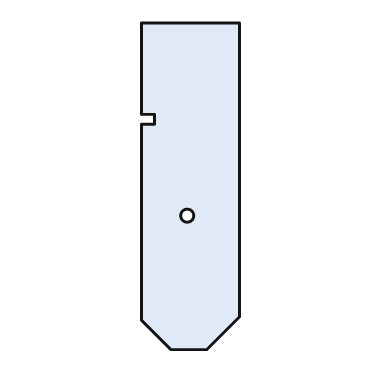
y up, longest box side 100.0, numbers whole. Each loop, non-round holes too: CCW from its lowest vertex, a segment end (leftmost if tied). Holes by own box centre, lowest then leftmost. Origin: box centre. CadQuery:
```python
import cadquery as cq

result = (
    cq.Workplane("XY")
    .moveTo(-6.0, -50.0)
    .lineTo(5.0, -50.0)
    .lineTo(15.0, -40.0)
    .lineTo(15.0, 50.0)
    .lineTo(-15.0, 50.0)
    .lineTo(-15.0, 22.0)
    .lineTo(-11.0, 22.0)
    .lineTo(-11.0, 19.0)
    .lineTo(-15.0, 19.0)
    .lineTo(-15.0, -41.0)
    .close()
    .moveTo(-1.0, -9.0)
    .circle(2.0)
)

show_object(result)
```